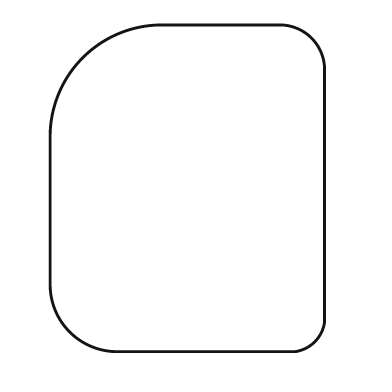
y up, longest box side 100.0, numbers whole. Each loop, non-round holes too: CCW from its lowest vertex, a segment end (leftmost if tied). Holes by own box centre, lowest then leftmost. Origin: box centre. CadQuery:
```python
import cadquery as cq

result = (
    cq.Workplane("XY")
    .moveTo(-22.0, -50.0)
    .lineTo(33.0, -50.0)
    .threePointArc((39.0, -47.0), (42.0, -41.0))
    .lineTo(42.0, 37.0)
    .threePointArc((38.0, 46.0), (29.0, 50.0))
    .lineTo(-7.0, 50.0)
    .threePointArc((-32.0, 40.0), (-42.0, 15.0))
    .lineTo(-42.0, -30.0)
    .threePointArc((-36.0, -44.0), (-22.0, -50.0))
    .close()
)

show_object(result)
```